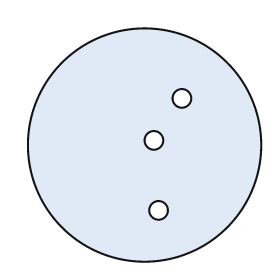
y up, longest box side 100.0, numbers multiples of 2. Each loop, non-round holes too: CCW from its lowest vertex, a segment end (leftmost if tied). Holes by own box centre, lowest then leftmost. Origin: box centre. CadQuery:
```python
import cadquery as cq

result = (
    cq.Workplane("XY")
    .moveTo(0.0, 0.0)
    .circle(50.0)
    .moveTo(6.0, -28.0)
    .circle(4.0)
    .moveTo(4.0, 2.0)
    .circle(4.0)
    .moveTo(16.0, 20.0)
    .circle(4.0)
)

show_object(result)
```